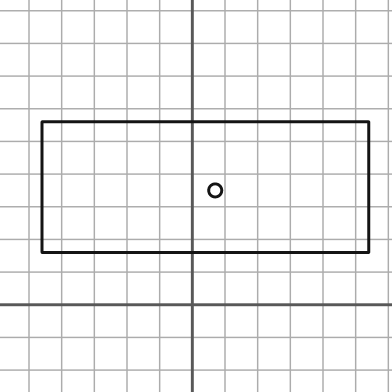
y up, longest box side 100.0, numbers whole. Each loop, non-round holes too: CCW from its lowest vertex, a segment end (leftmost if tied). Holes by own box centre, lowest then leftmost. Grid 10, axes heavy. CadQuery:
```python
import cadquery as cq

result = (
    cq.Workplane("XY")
    .moveTo(-46.0, 16.0)
    .lineTo(54.0, 16.0)
    .lineTo(54.0, 56.0)
    .lineTo(-46.0, 56.0)
    .close()
    .moveTo(7.0, 35.0)
    .circle(2.0)
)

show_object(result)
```